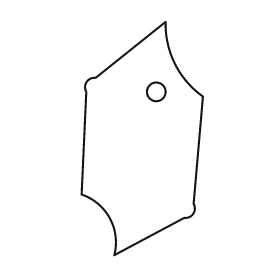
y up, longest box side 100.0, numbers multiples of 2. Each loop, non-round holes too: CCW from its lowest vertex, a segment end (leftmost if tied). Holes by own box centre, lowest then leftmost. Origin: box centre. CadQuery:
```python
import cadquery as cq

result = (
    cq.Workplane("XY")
    .moveTo(-12.0, -50.0)
    .lineTo(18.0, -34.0)
    .threePointArc((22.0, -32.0), (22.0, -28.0))
    .lineTo(26.0, 18.0)
    .threePointArc((14.0, 32.0), (10.0, 50.0))
    .lineTo(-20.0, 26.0)
    .threePointArc((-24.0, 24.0), (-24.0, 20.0))
    .lineTo(-26.0, -24.0)
    .threePointArc((-14.0, -34.0), (-12.0, -50.0))
    .close()
    .moveTo(6.0, 20.0)
    .circle(4.0)
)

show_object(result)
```